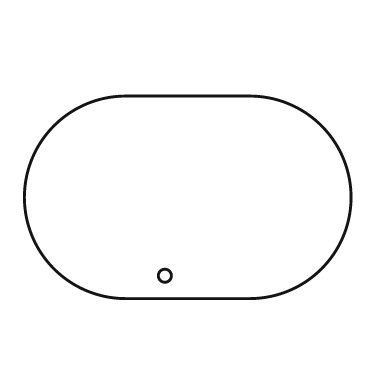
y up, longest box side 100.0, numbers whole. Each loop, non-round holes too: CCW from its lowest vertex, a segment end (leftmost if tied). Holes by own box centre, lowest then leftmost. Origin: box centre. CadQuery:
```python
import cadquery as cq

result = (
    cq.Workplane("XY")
    .moveTo(-19.0, -31.0)
    .lineTo(19.0, -31.0)
    .threePointArc((50.0, 0.0), (19.0, 31.0))
    .lineTo(-19.0, 31.0)
    .threePointArc((-50.0, 0.0), (-19.0, -31.0))
    .close()
    .moveTo(-7.0, -24.0)
    .circle(2.0)
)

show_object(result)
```